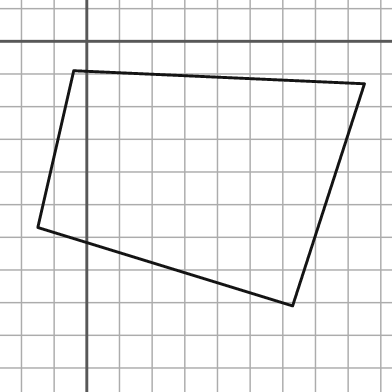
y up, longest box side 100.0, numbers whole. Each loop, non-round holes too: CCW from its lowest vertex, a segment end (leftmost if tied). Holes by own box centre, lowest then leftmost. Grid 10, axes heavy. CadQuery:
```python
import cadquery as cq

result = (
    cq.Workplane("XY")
    .moveTo(63.0, -81.0)
    .lineTo(85.0, -13.0)
    .lineTo(-4.0, -9.0)
    .lineTo(-15.0, -57.0)
    .close()
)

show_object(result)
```